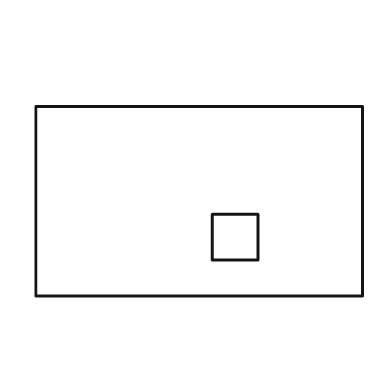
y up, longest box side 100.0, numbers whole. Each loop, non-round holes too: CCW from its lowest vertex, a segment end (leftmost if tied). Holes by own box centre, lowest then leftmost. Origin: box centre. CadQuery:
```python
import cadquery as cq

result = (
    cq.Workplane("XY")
    .moveTo(-50.0, -29.0)
    .lineTo(50.0, -29.0)
    .lineTo(50.0, 29.0)
    .lineTo(-50.0, 29.0)
    .close()
    .moveTo(4.0, -18.0)
    .lineTo(18.0, -18.0)
    .lineTo(18.0, -4.0)
    .lineTo(4.0, -4.0)
    .close()
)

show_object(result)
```